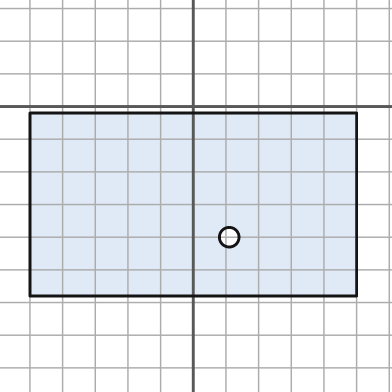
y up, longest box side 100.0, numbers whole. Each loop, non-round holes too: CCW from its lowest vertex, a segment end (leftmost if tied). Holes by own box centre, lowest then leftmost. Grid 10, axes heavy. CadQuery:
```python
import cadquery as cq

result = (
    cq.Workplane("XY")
    .moveTo(-50.0, -58.0)
    .lineTo(50.0, -58.0)
    .lineTo(50.0, -2.0)
    .lineTo(-50.0, -2.0)
    .close()
    .moveTo(11.0, -40.0)
    .circle(3.0)
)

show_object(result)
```